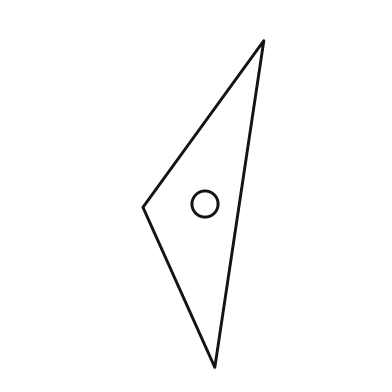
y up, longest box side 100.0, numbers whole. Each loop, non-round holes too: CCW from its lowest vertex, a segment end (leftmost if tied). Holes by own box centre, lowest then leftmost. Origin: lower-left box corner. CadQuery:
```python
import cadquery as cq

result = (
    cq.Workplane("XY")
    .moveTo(22.0, 0.0)
    .lineTo(37.0, 100.0)
    .lineTo(0.0, 49.0)
    .close()
    .moveTo(19.0, 50.0)
    .circle(4.0)
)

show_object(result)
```